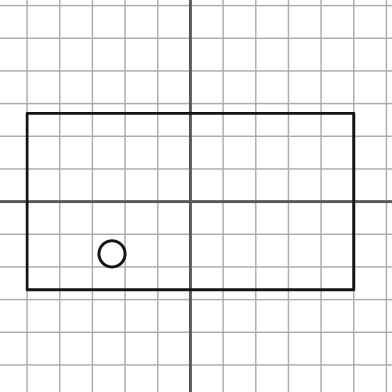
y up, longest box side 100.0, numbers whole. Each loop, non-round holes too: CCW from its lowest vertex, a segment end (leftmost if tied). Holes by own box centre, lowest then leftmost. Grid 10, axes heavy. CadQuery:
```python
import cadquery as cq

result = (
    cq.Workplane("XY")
    .moveTo(-50.0, -27.0)
    .lineTo(50.0, -27.0)
    .lineTo(50.0, 27.0)
    .lineTo(-50.0, 27.0)
    .close()
    .moveTo(-24.0, -16.0)
    .circle(4.0)
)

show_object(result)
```